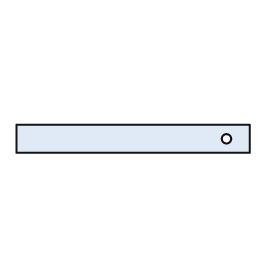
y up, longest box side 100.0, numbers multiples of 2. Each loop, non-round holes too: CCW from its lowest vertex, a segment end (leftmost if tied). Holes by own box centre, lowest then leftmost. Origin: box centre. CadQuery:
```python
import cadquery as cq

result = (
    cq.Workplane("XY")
    .moveTo(-50.0, -6.0)
    .lineTo(50.0, -6.0)
    .lineTo(50.0, 6.0)
    .lineTo(-50.0, 6.0)
    .close()
    .moveTo(40.0, 0.0)
    .circle(2.0)
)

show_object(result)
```